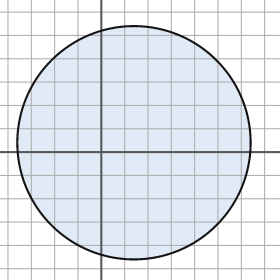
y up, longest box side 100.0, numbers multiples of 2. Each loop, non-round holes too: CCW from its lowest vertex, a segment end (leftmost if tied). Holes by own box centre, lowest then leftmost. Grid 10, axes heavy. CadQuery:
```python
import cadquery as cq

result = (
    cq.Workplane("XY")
    .moveTo(14.0, 4.0)
    .circle(50.0)
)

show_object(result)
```